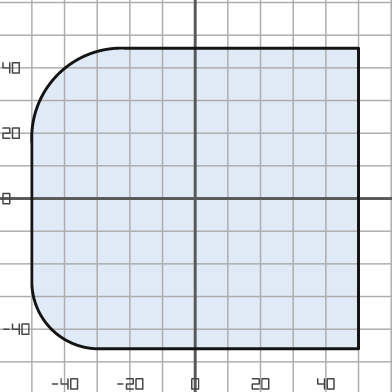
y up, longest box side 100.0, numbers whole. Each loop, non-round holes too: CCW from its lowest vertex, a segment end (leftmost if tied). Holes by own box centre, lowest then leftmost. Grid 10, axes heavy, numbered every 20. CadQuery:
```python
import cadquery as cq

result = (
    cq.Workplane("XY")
    .moveTo(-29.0, -46.0)
    .lineTo(50.0, -46.0)
    .lineTo(50.0, 46.0)
    .lineTo(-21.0, 46.0)
    .threePointArc((-42.0, 38.0), (-50.0, 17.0))
    .lineTo(-50.0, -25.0)
    .threePointArc((-44.0, -40.0), (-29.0, -46.0))
    .close()
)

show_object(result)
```